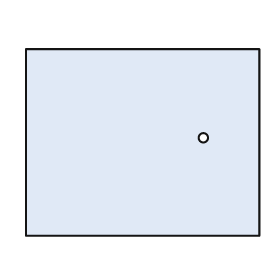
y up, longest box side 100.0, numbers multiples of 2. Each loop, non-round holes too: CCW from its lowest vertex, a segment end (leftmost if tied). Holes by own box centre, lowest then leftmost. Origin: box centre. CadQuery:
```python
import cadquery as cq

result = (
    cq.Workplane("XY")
    .moveTo(-50.0, -40.0)
    .lineTo(50.0, -40.0)
    .lineTo(50.0, 40.0)
    .lineTo(-50.0, 40.0)
    .close()
    .moveTo(26.0, 2.0)
    .circle(2.0)
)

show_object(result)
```